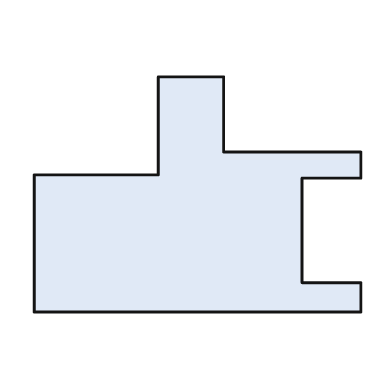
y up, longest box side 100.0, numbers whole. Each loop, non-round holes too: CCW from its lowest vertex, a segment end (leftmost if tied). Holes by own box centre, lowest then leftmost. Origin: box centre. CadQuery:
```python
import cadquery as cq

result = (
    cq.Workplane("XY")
    .moveTo(-50.0, -36.0)
    .lineTo(50.0, -36.0)
    .lineTo(50.0, -27.0)
    .lineTo(32.0, -27.0)
    .lineTo(32.0, 5.0)
    .lineTo(50.0, 5.0)
    .lineTo(50.0, 13.0)
    .lineTo(8.0, 13.0)
    .lineTo(8.0, 36.0)
    .lineTo(-12.0, 36.0)
    .lineTo(-12.0, 6.0)
    .lineTo(-50.0, 6.0)
    .close()
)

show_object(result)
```